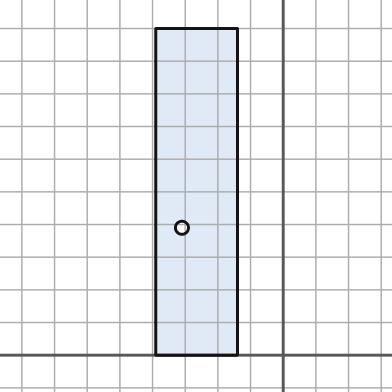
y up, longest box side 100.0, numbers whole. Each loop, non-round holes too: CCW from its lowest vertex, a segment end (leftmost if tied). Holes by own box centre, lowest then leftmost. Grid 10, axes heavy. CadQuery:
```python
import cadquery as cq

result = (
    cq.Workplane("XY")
    .moveTo(-39.0, 0.0)
    .lineTo(-14.0, 0.0)
    .lineTo(-14.0, 100.0)
    .lineTo(-39.0, 100.0)
    .close()
    .moveTo(-31.0, 39.0)
    .circle(2.0)
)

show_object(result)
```